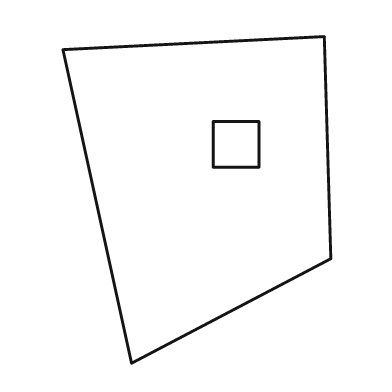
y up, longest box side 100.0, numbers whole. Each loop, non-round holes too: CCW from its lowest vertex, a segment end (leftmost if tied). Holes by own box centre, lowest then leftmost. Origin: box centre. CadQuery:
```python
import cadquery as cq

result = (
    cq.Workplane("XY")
    .moveTo(-20.0, -50.0)
    .lineTo(41.0, -18.0)
    .lineTo(39.0, 50.0)
    .lineTo(-41.0, 46.0)
    .close()
    .moveTo(5.0, 10.0)
    .lineTo(19.0, 10.0)
    .lineTo(19.0, 24.0)
    .lineTo(5.0, 24.0)
    .close()
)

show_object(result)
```